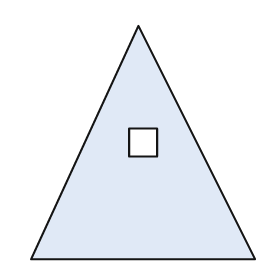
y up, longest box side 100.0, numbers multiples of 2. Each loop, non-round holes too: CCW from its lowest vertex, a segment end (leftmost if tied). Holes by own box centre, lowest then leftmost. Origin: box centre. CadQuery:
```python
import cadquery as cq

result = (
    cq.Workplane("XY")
    .moveTo(-48.0, -50.0)
    .lineTo(48.0, -50.0)
    .lineTo(-2.0, 50.0)
    .close()
    .moveTo(-6.0, -6.0)
    .lineTo(6.0, -6.0)
    .lineTo(6.0, 6.0)
    .lineTo(-6.0, 6.0)
    .close()
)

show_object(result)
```